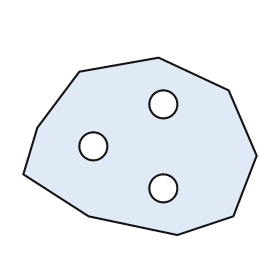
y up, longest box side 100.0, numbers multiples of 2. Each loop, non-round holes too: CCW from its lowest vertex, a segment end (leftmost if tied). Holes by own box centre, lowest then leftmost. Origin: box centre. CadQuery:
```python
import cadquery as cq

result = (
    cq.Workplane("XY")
    .moveTo(16.0, -38.0)
    .lineTo(40.0, -30.0)
    .lineTo(50.0, -4.0)
    .lineTo(38.0, 24.0)
    .lineTo(8.0, 38.0)
    .lineTo(-26.0, 32.0)
    .lineTo(-44.0, 8.0)
    .lineTo(-50.0, -12.0)
    .lineTo(-22.0, -30.0)
    .close()
    .moveTo(10.0, -18.0)
    .circle(6.0)
    .moveTo(-20.0, 0.0)
    .circle(6.0)
    .moveTo(10.0, 18.0)
    .circle(6.0)
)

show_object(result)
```